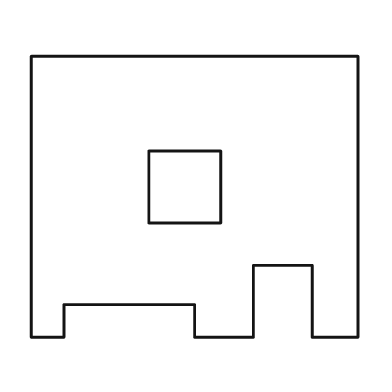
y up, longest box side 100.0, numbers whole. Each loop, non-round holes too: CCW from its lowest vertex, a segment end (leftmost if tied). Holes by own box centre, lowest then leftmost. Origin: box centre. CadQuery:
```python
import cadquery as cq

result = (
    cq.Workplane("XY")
    .moveTo(-50.0, -43.0)
    .lineTo(-40.0, -43.0)
    .lineTo(-40.0, -33.0)
    .lineTo(0.0, -33.0)
    .lineTo(0.0, -43.0)
    .lineTo(18.0, -43.0)
    .lineTo(18.0, -21.0)
    .lineTo(36.0, -21.0)
    .lineTo(36.0, -43.0)
    .lineTo(50.0, -43.0)
    .lineTo(50.0, 43.0)
    .lineTo(-50.0, 43.0)
    .close()
    .moveTo(-14.0, -8.0)
    .lineTo(8.0, -8.0)
    .lineTo(8.0, 14.0)
    .lineTo(-14.0, 14.0)
    .close()
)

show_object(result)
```